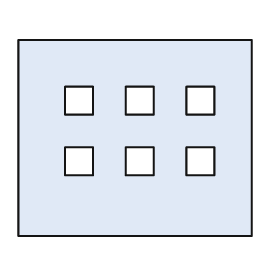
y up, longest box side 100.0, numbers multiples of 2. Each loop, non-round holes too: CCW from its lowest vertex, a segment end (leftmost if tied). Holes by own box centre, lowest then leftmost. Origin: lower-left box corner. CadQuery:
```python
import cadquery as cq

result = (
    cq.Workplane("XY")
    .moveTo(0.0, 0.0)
    .lineTo(100.0, 0.0)
    .lineTo(100.0, 84.0)
    .lineTo(0.0, 84.0)
    .close()
    .moveTo(20.0, 26.0)
    .lineTo(32.0, 26.0)
    .lineTo(32.0, 38.0)
    .lineTo(20.0, 38.0)
    .close()
    .moveTo(46.0, 26.0)
    .lineTo(58.0, 26.0)
    .lineTo(58.0, 38.0)
    .lineTo(46.0, 38.0)
    .close()
    .moveTo(72.0, 26.0)
    .lineTo(84.0, 26.0)
    .lineTo(84.0, 38.0)
    .lineTo(72.0, 38.0)
    .close()
    .moveTo(20.0, 52.0)
    .lineTo(32.0, 52.0)
    .lineTo(32.0, 64.0)
    .lineTo(20.0, 64.0)
    .close()
    .moveTo(46.0, 52.0)
    .lineTo(58.0, 52.0)
    .lineTo(58.0, 64.0)
    .lineTo(46.0, 64.0)
    .close()
    .moveTo(72.0, 52.0)
    .lineTo(84.0, 52.0)
    .lineTo(84.0, 64.0)
    .lineTo(72.0, 64.0)
    .close()
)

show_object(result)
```